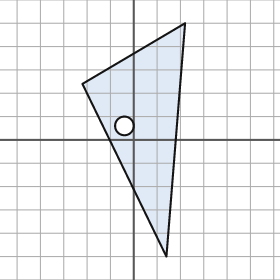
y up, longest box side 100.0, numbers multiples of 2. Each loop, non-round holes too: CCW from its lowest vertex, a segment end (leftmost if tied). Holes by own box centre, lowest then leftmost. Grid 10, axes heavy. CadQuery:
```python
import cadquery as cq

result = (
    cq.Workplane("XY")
    .moveTo(14.0, -50.0)
    .lineTo(22.0, 50.0)
    .lineTo(-22.0, 24.0)
    .close()
    .moveTo(-4.0, 6.0)
    .circle(4.0)
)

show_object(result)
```